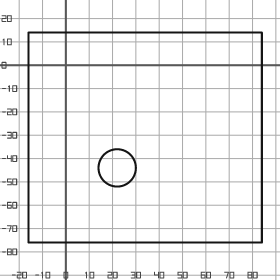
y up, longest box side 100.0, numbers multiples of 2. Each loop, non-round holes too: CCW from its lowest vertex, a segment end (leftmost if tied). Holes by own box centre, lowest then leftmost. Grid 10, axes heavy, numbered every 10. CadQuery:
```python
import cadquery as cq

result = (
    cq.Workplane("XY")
    .moveTo(-16.0, -76.0)
    .lineTo(84.0, -76.0)
    .lineTo(84.0, 14.0)
    .lineTo(-16.0, 14.0)
    .close()
    .moveTo(22.0, -44.0)
    .circle(8.0)
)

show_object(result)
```